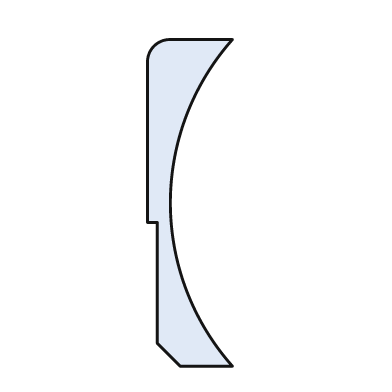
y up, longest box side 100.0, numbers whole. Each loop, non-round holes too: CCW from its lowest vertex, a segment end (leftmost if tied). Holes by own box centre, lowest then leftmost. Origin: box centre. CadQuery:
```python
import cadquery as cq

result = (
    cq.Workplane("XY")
    .moveTo(-3.0, -50.0)
    .lineTo(13.0, -50.0)
    .threePointArc((-6.0, 0.0), (13.0, 50.0))
    .lineTo(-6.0, 50.0)
    .threePointArc((-11.0, 48.0), (-13.0, 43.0))
    .lineTo(-13.0, -6.0)
    .lineTo(-10.0, -6.0)
    .lineTo(-10.0, -43.0)
    .close()
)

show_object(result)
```